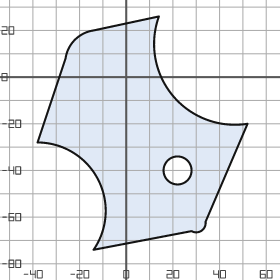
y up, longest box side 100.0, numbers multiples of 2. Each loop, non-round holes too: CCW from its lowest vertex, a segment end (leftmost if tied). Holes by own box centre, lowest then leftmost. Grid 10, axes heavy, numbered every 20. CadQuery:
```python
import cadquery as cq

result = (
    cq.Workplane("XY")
    .moveTo(-14.0, -74.0)
    .lineTo(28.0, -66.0)
    .threePointArc((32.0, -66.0), (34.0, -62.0))
    .lineTo(52.0, -20.0)
    .threePointArc((20.0, -8.0), (14.0, 26.0))
    .lineTo(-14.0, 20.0)
    .threePointArc((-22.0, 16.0), (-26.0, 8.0))
    .lineTo(-38.0, -28.0)
    .threePointArc((-12.0, -44.0), (-14.0, -74.0))
    .close()
    .moveTo(22.0, -40.0)
    .circle(6.0)
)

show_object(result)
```